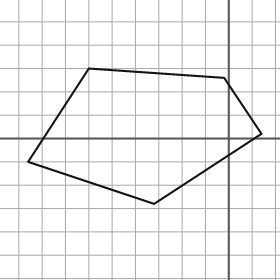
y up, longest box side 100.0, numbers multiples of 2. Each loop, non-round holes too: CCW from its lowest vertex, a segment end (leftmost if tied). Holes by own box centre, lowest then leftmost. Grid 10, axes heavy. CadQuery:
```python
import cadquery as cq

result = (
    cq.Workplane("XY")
    .moveTo(-32.0, -28.0)
    .lineTo(14.0, 2.0)
    .lineTo(-2.0, 26.0)
    .lineTo(-60.0, 30.0)
    .lineTo(-86.0, -10.0)
    .close()
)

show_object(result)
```